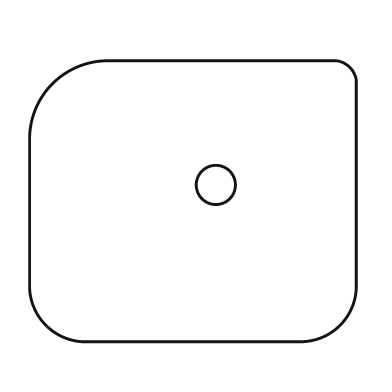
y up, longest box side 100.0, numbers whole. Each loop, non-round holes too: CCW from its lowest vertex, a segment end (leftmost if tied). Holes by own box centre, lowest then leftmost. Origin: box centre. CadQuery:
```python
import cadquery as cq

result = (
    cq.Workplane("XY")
    .moveTo(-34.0, -43.0)
    .lineTo(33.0, -43.0)
    .threePointArc((45.0, -38.0), (50.0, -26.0))
    .lineTo(50.0, 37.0)
    .threePointArc((48.0, 41.0), (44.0, 43.0))
    .lineTo(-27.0, 43.0)
    .threePointArc((-43.0, 36.0), (-50.0, 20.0))
    .lineTo(-50.0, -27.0)
    .threePointArc((-45.0, -38.0), (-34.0, -43.0))
    .close()
    .moveTo(7.0, 5.0)
    .circle(6.0)
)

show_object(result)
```